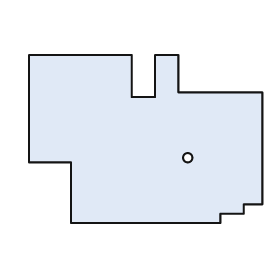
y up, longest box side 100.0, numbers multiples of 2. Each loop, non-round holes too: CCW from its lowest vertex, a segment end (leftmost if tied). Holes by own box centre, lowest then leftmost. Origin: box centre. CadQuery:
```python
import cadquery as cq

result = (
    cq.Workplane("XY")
    .moveTo(-32.0, -36.0)
    .lineTo(32.0, -36.0)
    .lineTo(32.0, -32.0)
    .lineTo(42.0, -32.0)
    .lineTo(42.0, -28.0)
    .lineTo(50.0, -28.0)
    .lineTo(50.0, 20.0)
    .lineTo(14.0, 20.0)
    .lineTo(14.0, 36.0)
    .lineTo(4.0, 36.0)
    .lineTo(4.0, 18.0)
    .lineTo(-6.0, 18.0)
    .lineTo(-6.0, 36.0)
    .lineTo(-50.0, 36.0)
    .lineTo(-50.0, -10.0)
    .lineTo(-32.0, -10.0)
    .close()
    .moveTo(18.0, -8.0)
    .circle(2.0)
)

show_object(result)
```